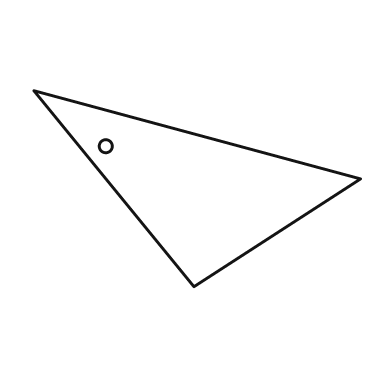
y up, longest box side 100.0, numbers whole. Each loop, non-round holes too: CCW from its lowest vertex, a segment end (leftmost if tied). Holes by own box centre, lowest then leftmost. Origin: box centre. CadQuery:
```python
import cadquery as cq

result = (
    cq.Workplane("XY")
    .moveTo(-1.0, -30.0)
    .lineTo(50.0, 3.0)
    .lineTo(-50.0, 30.0)
    .close()
    .moveTo(-28.0, 13.0)
    .circle(2.0)
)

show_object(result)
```